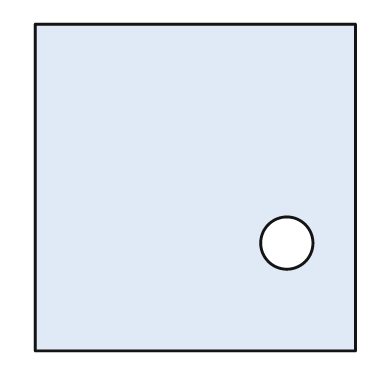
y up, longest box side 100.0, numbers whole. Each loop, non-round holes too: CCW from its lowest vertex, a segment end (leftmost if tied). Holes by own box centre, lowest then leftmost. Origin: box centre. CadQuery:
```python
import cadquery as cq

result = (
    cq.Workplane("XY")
    .moveTo(-49.0, -50.0)
    .lineTo(49.0, -50.0)
    .lineTo(49.0, 50.0)
    .lineTo(-49.0, 50.0)
    .close()
    .moveTo(28.0, -17.0)
    .circle(8.0)
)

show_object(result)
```